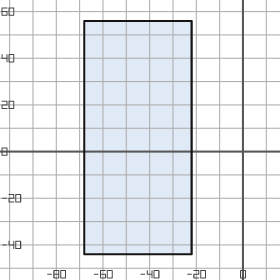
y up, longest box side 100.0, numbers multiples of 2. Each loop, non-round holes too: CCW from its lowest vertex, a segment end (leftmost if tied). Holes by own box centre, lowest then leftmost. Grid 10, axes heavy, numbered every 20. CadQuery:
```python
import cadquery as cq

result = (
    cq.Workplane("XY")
    .moveTo(-68.0, -44.0)
    .lineTo(-22.0, -44.0)
    .lineTo(-22.0, 56.0)
    .lineTo(-68.0, 56.0)
    .close()
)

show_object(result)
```